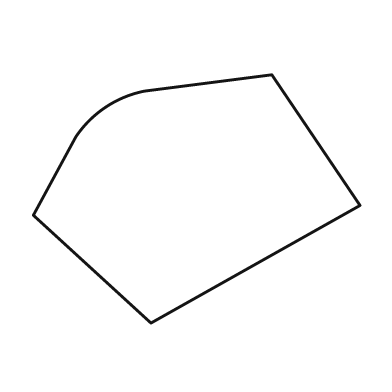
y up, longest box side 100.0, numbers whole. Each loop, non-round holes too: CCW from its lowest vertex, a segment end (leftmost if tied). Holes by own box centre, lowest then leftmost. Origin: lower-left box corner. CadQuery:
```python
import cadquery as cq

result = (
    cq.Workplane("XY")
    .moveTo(36.0, 0.0)
    .lineTo(100.0, 36.0)
    .lineTo(73.0, 76.0)
    .lineTo(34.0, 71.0)
    .threePointArc((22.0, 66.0), (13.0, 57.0))
    .lineTo(0.0, 33.0)
    .close()
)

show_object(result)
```